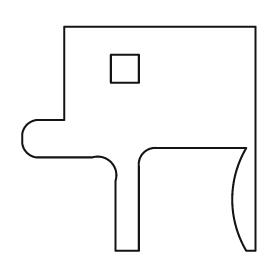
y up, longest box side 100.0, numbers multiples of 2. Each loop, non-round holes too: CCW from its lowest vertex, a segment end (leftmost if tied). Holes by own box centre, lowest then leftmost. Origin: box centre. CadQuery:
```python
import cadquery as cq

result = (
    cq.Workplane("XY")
    .moveTo(-10.0, -48.0)
    .lineTo(0.0, -48.0)
    .lineTo(0.0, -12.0)
    .threePointArc((2.0, -6.0), (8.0, -4.0))
    .lineTo(46.0, -4.0)
    .threePointArc((40.0, -26.0), (46.0, -48.0))
    .lineTo(50.0, -48.0)
    .lineTo(50.0, 48.0)
    .lineTo(-32.0, 48.0)
    .lineTo(-32.0, 8.0)
    .lineTo(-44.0, 8.0)
    .threePointArc((-48.0, 6.0), (-50.0, 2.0))
    .lineTo(-50.0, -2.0)
    .threePointArc((-48.0, -6.0), (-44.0, -8.0))
    .lineTo(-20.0, -8.0)
    .threePointArc((-12.0, -10.0), (-10.0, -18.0))
    .close()
    .moveTo(-12.0, 24.0)
    .lineTo(0.0, 24.0)
    .lineTo(0.0, 36.0)
    .lineTo(-12.0, 36.0)
    .close()
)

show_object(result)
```